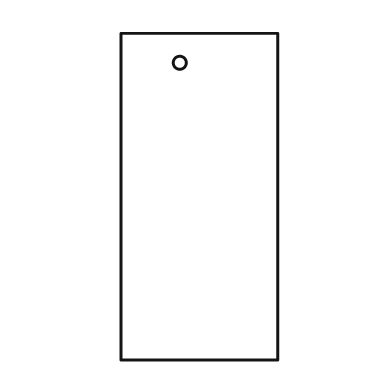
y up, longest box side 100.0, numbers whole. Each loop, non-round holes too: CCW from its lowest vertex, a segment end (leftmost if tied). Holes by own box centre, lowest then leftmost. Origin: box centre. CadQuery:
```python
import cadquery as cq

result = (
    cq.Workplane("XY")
    .moveTo(-24.0, -50.0)
    .lineTo(24.0, -50.0)
    .lineTo(24.0, 50.0)
    .lineTo(-24.0, 50.0)
    .close()
    .moveTo(-6.0, 41.0)
    .circle(2.0)
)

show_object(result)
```